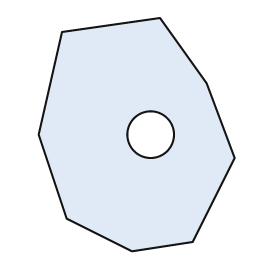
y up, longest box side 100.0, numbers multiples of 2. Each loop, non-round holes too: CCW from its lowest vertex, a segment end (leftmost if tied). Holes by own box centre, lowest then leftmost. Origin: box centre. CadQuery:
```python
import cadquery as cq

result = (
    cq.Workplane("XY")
    .moveTo(-2.0, -50.0)
    .lineTo(24.0, -46.0)
    .lineTo(42.0, -10.0)
    .lineTo(30.0, 22.0)
    .lineTo(10.0, 50.0)
    .lineTo(-32.0, 44.0)
    .lineTo(-42.0, 0.0)
    .lineTo(-30.0, -36.0)
    .close()
    .moveTo(6.0, 0.0)
    .circle(10.0)
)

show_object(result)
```